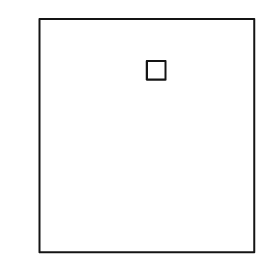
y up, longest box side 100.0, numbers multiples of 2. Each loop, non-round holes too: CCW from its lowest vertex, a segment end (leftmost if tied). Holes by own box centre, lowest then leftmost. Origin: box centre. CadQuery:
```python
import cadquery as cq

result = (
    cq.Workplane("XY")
    .moveTo(-46.0, -50.0)
    .lineTo(46.0, -50.0)
    .lineTo(46.0, 50.0)
    .lineTo(-46.0, 50.0)
    .close()
    .moveTo(0.0, 24.0)
    .lineTo(8.0, 24.0)
    .lineTo(8.0, 32.0)
    .lineTo(0.0, 32.0)
    .close()
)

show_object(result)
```